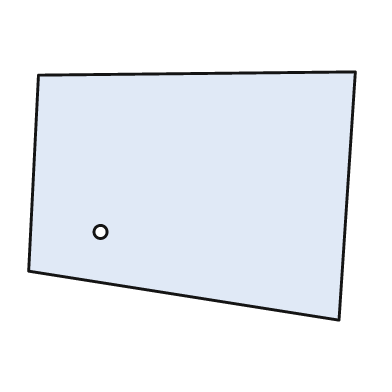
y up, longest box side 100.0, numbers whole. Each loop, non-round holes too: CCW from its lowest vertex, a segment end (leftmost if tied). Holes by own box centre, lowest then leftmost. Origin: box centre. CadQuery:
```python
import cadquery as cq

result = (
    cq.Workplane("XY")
    .moveTo(45.0, -38.0)
    .lineTo(50.0, 38.0)
    .lineTo(-47.0, 37.0)
    .lineTo(-50.0, -23.0)
    .close()
    .moveTo(-28.0, -11.0)
    .circle(2.0)
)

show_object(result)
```